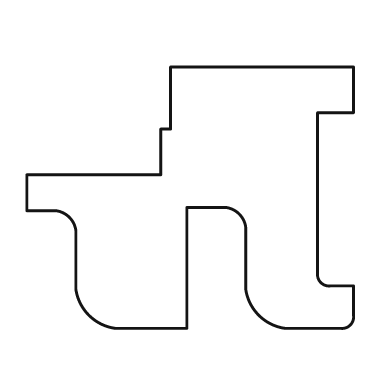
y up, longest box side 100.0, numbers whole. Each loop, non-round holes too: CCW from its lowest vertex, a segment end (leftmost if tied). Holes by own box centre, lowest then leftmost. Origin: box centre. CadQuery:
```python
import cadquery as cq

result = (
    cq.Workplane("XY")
    .moveTo(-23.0, -40.0)
    .lineTo(-1.0, -40.0)
    .lineTo(-1.0, -3.0)
    .lineTo(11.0, -3.0)
    .threePointArc((15.0, -5.0), (17.0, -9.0))
    .lineTo(17.0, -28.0)
    .threePointArc((21.0, -36.0), (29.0, -40.0))
    .lineTo(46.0, -40.0)
    .threePointArc((49.0, -39.0), (50.0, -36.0))
    .lineTo(50.0, -27.0)
    .lineTo(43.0, -27.0)
    .threePointArc((40.0, -26.0), (39.0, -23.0))
    .lineTo(39.0, 26.0)
    .lineTo(50.0, 26.0)
    .lineTo(50.0, 40.0)
    .lineTo(-6.0, 40.0)
    .lineTo(-6.0, 21.0)
    .lineTo(-9.0, 21.0)
    .lineTo(-9.0, 7.0)
    .lineTo(-50.0, 7.0)
    .lineTo(-50.0, -4.0)
    .lineTo(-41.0, -4.0)
    .threePointArc((-37.0, -6.0), (-35.0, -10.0))
    .lineTo(-35.0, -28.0)
    .threePointArc((-31.0, -36.0), (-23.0, -40.0))
    .close()
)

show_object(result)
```